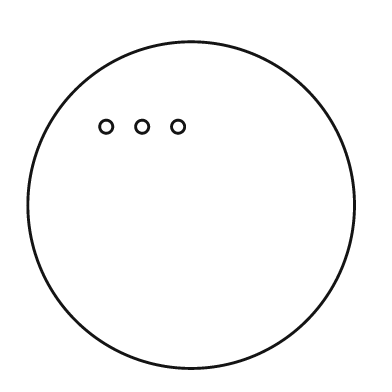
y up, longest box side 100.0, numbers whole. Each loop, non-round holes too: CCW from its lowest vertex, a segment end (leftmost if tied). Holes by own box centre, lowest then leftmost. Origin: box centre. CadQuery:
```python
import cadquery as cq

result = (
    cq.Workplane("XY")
    .moveTo(0.0, 0.0)
    .circle(50.0)
    .moveTo(-26.0, 24.0)
    .circle(2.0)
    .moveTo(-15.0, 24.0)
    .circle(2.0)
    .moveTo(-4.0, 24.0)
    .circle(2.0)
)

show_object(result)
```